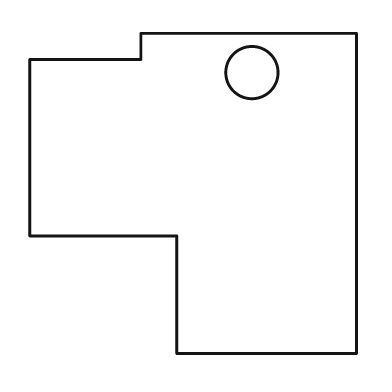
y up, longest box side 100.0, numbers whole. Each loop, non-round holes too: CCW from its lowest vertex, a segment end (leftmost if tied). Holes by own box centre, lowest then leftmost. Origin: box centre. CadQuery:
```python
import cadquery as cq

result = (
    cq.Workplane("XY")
    .moveTo(-5.0, -49.0)
    .lineTo(50.0, -49.0)
    .lineTo(50.0, 49.0)
    .lineTo(-16.0, 49.0)
    .lineTo(-16.0, 41.0)
    .lineTo(-50.0, 41.0)
    .lineTo(-50.0, -13.0)
    .lineTo(-5.0, -13.0)
    .close()
    .moveTo(18.0, 37.0)
    .circle(8.0)
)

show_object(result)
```